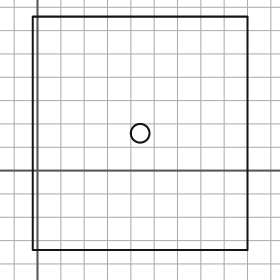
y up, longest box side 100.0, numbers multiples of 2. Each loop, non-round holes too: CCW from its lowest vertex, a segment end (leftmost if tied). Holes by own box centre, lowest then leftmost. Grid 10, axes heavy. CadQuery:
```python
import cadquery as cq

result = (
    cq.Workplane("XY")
    .moveTo(-2.0, -34.0)
    .lineTo(90.0, -34.0)
    .lineTo(90.0, 66.0)
    .lineTo(-2.0, 66.0)
    .close()
    .moveTo(44.0, 16.0)
    .circle(4.0)
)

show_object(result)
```